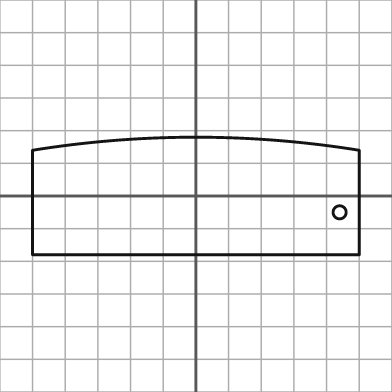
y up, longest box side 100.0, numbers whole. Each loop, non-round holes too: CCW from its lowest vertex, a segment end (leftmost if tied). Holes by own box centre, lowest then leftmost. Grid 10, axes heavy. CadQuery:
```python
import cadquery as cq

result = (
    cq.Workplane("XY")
    .moveTo(-50.0, -18.0)
    .lineTo(50.0, -18.0)
    .lineTo(50.0, 14.0)
    .threePointArc((0.0, 18.0), (-50.0, 14.0))
    .close()
    .moveTo(44.0, -5.0)
    .circle(2.0)
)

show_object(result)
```